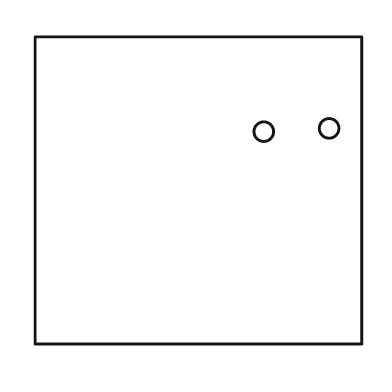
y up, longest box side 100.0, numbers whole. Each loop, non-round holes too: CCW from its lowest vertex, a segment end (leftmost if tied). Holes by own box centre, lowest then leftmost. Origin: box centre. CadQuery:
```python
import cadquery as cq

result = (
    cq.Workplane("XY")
    .moveTo(-50.0, -47.0)
    .lineTo(50.0, -47.0)
    .lineTo(50.0, 47.0)
    .lineTo(-50.0, 47.0)
    .close()
    .moveTo(20.0, 18.0)
    .circle(3.0)
    .moveTo(40.0, 19.0)
    .circle(3.0)
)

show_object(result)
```